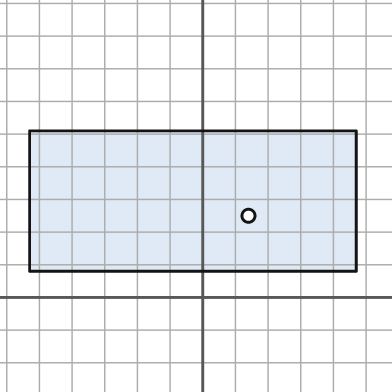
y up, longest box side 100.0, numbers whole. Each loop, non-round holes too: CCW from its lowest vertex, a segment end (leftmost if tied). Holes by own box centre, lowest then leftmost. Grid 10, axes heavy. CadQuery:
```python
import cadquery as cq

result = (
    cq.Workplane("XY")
    .moveTo(-53.0, 8.0)
    .lineTo(47.0, 8.0)
    .lineTo(47.0, 51.0)
    .lineTo(-53.0, 51.0)
    .close()
    .moveTo(14.0, 25.0)
    .circle(2.0)
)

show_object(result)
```